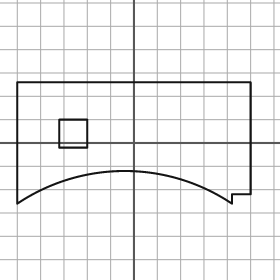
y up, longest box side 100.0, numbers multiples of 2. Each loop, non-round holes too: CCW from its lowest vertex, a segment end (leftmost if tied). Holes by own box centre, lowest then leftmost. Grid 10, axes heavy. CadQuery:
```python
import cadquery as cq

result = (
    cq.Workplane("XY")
    .moveTo(-50.0, -26.0)
    .threePointArc((-4.0, -12.0), (42.0, -26.0))
    .lineTo(42.0, -22.0)
    .lineTo(50.0, -22.0)
    .lineTo(50.0, 26.0)
    .lineTo(-50.0, 26.0)
    .close()
    .moveTo(-32.0, -2.0)
    .lineTo(-20.0, -2.0)
    .lineTo(-20.0, 10.0)
    .lineTo(-32.0, 10.0)
    .close()
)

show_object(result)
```